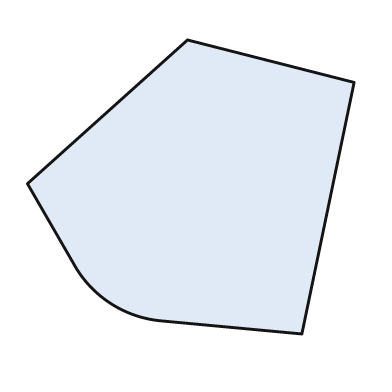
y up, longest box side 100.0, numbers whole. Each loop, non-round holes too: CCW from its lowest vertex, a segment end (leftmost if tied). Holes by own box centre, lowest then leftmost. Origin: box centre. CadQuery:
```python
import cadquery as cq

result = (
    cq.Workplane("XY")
    .moveTo(34.0, -45.0)
    .lineTo(50.0, 32.0)
    .lineTo(-1.0, 45.0)
    .lineTo(-50.0, 1.0)
    .lineTo(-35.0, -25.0)
    .threePointArc((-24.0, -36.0), (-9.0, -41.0))
    .close()
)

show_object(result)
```